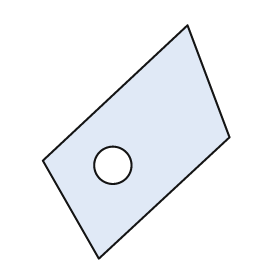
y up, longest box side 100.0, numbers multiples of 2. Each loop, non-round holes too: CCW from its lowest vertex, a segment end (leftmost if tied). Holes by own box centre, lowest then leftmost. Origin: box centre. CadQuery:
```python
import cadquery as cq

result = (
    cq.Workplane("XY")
    .moveTo(-16.0, -50.0)
    .lineTo(40.0, 2.0)
    .lineTo(22.0, 50.0)
    .lineTo(-40.0, -8.0)
    .close()
    .moveTo(-10.0, -10.0)
    .circle(8.0)
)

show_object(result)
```